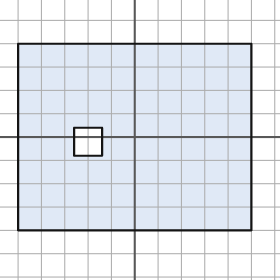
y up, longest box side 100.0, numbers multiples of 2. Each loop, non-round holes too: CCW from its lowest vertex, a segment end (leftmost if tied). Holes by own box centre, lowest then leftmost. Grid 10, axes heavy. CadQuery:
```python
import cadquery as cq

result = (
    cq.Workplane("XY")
    .moveTo(-50.0, -40.0)
    .lineTo(50.0, -40.0)
    .lineTo(50.0, 40.0)
    .lineTo(-50.0, 40.0)
    .close()
    .moveTo(-26.0, -8.0)
    .lineTo(-14.0, -8.0)
    .lineTo(-14.0, 4.0)
    .lineTo(-26.0, 4.0)
    .close()
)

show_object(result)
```